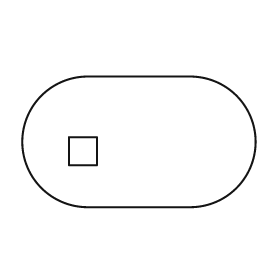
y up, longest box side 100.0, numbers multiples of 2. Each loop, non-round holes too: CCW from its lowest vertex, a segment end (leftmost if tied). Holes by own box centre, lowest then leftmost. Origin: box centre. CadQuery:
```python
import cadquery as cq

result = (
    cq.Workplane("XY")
    .moveTo(-22.0, -28.0)
    .lineTo(22.0, -28.0)
    .threePointArc((50.0, 0.0), (22.0, 28.0))
    .lineTo(-22.0, 28.0)
    .threePointArc((-50.0, 0.0), (-22.0, -28.0))
    .close()
    .moveTo(-30.0, -10.0)
    .lineTo(-18.0, -10.0)
    .lineTo(-18.0, 2.0)
    .lineTo(-30.0, 2.0)
    .close()
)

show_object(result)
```